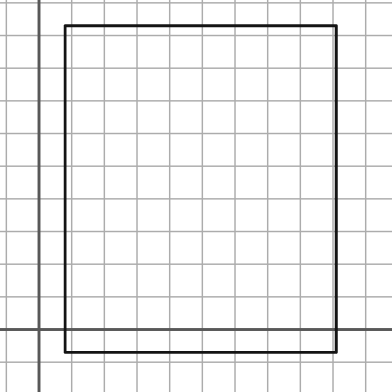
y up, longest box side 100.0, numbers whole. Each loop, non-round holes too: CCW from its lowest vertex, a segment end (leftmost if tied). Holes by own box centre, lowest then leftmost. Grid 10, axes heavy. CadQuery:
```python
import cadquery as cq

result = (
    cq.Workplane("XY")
    .moveTo(8.0, -7.0)
    .lineTo(91.0, -7.0)
    .lineTo(91.0, 93.0)
    .lineTo(8.0, 93.0)
    .close()
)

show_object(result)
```